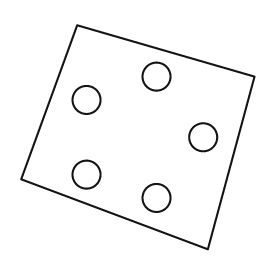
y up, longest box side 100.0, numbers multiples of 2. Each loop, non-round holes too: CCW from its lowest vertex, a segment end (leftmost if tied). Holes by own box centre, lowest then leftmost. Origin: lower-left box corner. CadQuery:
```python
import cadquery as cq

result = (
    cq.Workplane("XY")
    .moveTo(80.0, 0.0)
    .lineTo(100.0, 74.0)
    .lineTo(24.0, 96.0)
    .lineTo(0.0, 30.0)
    .close()
    .moveTo(58.0, 22.0)
    .circle(6.0)
    .moveTo(28.0, 32.0)
    .circle(6.0)
    .moveTo(78.0, 48.0)
    .circle(6.0)
    .moveTo(28.0, 64.0)
    .circle(6.0)
    .moveTo(58.0, 74.0)
    .circle(6.0)
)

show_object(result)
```